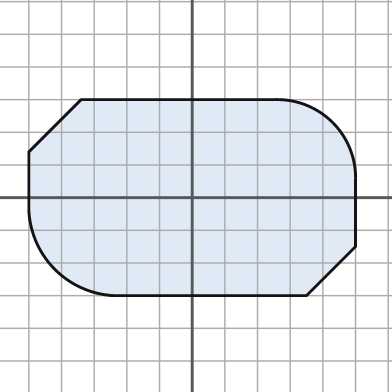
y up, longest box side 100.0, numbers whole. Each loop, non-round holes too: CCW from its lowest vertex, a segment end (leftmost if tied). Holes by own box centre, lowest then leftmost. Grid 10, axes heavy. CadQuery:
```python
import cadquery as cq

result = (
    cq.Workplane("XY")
    .moveTo(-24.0, -30.0)
    .lineTo(35.0, -30.0)
    .lineTo(50.0, -15.0)
    .lineTo(50.0, 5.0)
    .threePointArc((43.0, 23.0), (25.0, 30.0))
    .lineTo(-34.0, 30.0)
    .lineTo(-50.0, 14.0)
    .lineTo(-50.0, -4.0)
    .threePointArc((-42.0, -22.0), (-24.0, -30.0))
    .close()
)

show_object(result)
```